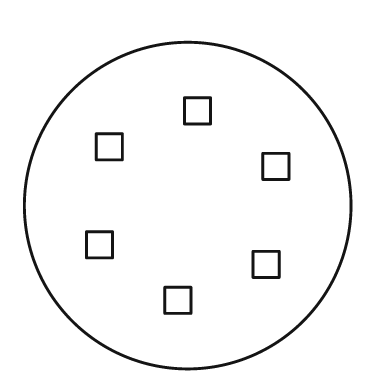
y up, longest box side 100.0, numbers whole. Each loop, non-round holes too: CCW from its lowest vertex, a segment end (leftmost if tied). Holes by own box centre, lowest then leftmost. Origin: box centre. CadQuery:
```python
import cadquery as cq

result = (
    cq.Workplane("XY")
    .moveTo(0.0, 0.0)
    .circle(50.0)
    .moveTo(-7.0, -33.0)
    .lineTo(1.0, -33.0)
    .lineTo(1.0, -25.0)
    .lineTo(-7.0, -25.0)
    .close()
    .moveTo(20.0, -22.0)
    .lineTo(28.0, -22.0)
    .lineTo(28.0, -14.0)
    .lineTo(20.0, -14.0)
    .close()
    .moveTo(-31.0, -16.0)
    .lineTo(-23.0, -16.0)
    .lineTo(-23.0, -8.0)
    .lineTo(-31.0, -8.0)
    .close()
    .moveTo(23.0, 8.0)
    .lineTo(31.0, 8.0)
    .lineTo(31.0, 16.0)
    .lineTo(23.0, 16.0)
    .close()
    .moveTo(-28.0, 14.0)
    .lineTo(-20.0, 14.0)
    .lineTo(-20.0, 22.0)
    .lineTo(-28.0, 22.0)
    .close()
    .moveTo(-1.0, 25.0)
    .lineTo(7.0, 25.0)
    .lineTo(7.0, 33.0)
    .lineTo(-1.0, 33.0)
    .close()
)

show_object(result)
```